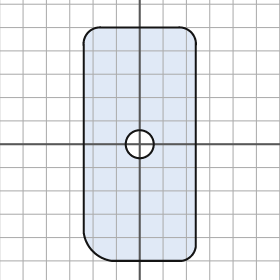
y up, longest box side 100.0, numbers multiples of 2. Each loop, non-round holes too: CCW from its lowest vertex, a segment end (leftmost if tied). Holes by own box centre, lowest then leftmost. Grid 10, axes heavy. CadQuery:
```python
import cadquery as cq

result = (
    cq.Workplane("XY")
    .moveTo(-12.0, -50.0)
    .lineTo(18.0, -50.0)
    .threePointArc((22.0, -48.0), (24.0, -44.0))
    .lineTo(24.0, 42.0)
    .threePointArc((22.0, 48.0), (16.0, 50.0))
    .lineTo(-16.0, 50.0)
    .threePointArc((-22.0, 48.0), (-24.0, 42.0))
    .lineTo(-24.0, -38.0)
    .threePointArc((-20.0, -46.0), (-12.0, -50.0))
    .close()
    .moveTo(0.0, 0.0)
    .circle(6.0)
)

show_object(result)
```